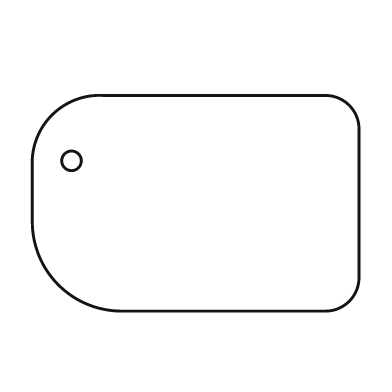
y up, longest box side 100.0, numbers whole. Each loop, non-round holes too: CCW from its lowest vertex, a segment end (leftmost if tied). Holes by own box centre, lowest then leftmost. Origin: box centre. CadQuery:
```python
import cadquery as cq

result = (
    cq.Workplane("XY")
    .moveTo(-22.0, -33.0)
    .lineTo(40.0, -33.0)
    .threePointArc((47.0, -30.0), (50.0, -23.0))
    .lineTo(50.0, 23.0)
    .threePointArc((47.0, 30.0), (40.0, 33.0))
    .lineTo(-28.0, 33.0)
    .threePointArc((-44.0, 27.0), (-50.0, 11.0))
    .lineTo(-50.0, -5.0)
    .threePointArc((-42.0, -25.0), (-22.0, -33.0))
    .close()
    .moveTo(-38.0, 13.0)
    .circle(3.0)
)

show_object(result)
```